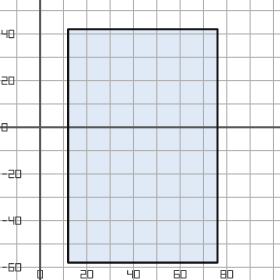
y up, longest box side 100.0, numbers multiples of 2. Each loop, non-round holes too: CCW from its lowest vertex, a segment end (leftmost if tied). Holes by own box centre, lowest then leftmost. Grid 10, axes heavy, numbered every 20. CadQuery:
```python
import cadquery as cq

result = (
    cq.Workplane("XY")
    .moveTo(12.0, -58.0)
    .lineTo(76.0, -58.0)
    .lineTo(76.0, 42.0)
    .lineTo(12.0, 42.0)
    .close()
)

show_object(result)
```